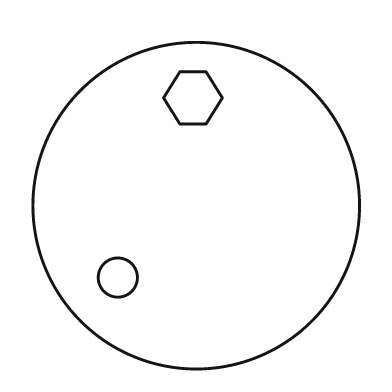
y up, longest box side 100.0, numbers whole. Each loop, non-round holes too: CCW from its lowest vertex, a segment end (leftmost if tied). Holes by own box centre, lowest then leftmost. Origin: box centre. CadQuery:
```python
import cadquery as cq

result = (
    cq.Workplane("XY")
    .moveTo(0.0, 0.0)
    .circle(50.0)
    .moveTo(-24.0, -22.0)
    .circle(6.0)
    .moveTo(-5.0, 25.0)
    .lineTo(3.0, 25.0)
    .lineTo(8.0, 33.0)
    .lineTo(3.0, 41.0)
    .lineTo(-5.0, 41.0)
    .lineTo(-10.0, 33.0)
    .close()
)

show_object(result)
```